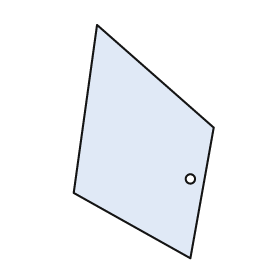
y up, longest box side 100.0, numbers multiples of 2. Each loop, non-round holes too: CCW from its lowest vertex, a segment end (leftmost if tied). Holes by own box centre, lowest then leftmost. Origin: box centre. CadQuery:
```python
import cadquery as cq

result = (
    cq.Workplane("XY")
    .moveTo(20.0, -50.0)
    .lineTo(30.0, 6.0)
    .lineTo(-20.0, 50.0)
    .lineTo(-30.0, -22.0)
    .close()
    .moveTo(20.0, -16.0)
    .circle(2.0)
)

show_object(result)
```